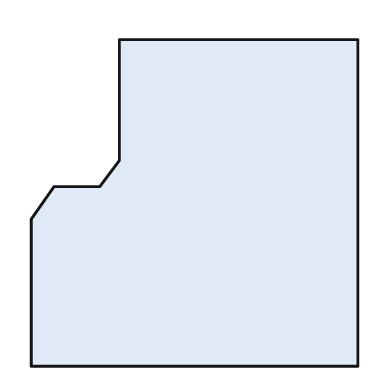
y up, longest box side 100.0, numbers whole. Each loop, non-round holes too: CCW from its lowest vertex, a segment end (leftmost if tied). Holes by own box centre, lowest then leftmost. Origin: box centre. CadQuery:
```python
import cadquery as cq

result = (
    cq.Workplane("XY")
    .moveTo(-50.0, -50.0)
    .lineTo(50.0, -50.0)
    .lineTo(50.0, 50.0)
    .lineTo(-23.0, 50.0)
    .lineTo(-23.0, 13.0)
    .lineTo(-29.0, 5.0)
    .lineTo(-43.0, 5.0)
    .lineTo(-50.0, -5.0)
    .close()
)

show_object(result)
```